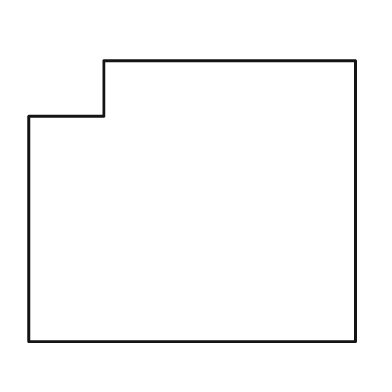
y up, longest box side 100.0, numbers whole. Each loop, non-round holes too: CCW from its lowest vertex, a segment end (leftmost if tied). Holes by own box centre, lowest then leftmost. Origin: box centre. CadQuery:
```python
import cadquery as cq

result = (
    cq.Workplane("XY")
    .moveTo(-50.0, -43.0)
    .lineTo(50.0, -43.0)
    .lineTo(50.0, 43.0)
    .lineTo(-27.0, 43.0)
    .lineTo(-27.0, 26.0)
    .lineTo(-50.0, 26.0)
    .close()
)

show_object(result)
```